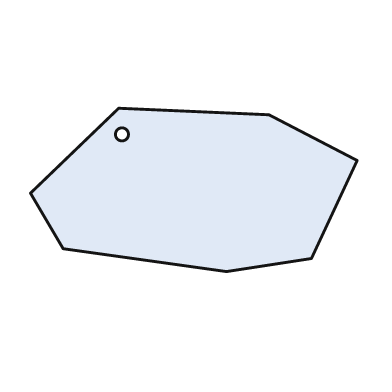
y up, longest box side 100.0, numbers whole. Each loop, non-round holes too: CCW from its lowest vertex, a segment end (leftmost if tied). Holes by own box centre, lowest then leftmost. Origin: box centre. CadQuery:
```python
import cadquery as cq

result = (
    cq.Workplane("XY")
    .moveTo(10.0, -25.0)
    .lineTo(36.0, -21.0)
    .lineTo(50.0, 9.0)
    .lineTo(23.0, 23.0)
    .lineTo(-23.0, 25.0)
    .lineTo(-50.0, -1.0)
    .lineTo(-40.0, -18.0)
    .close()
    .moveTo(-22.0, 17.0)
    .circle(2.0)
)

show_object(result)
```